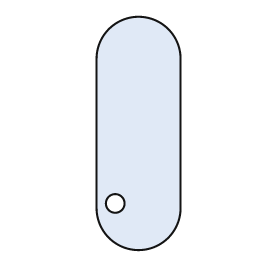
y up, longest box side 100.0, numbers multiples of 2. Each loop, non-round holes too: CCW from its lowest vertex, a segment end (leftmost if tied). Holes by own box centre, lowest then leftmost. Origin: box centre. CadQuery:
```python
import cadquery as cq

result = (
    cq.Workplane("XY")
    .moveTo(-18.0, -32.0)
    .threePointArc((0.0, -50.0), (18.0, -32.0))
    .lineTo(18.0, 32.0)
    .threePointArc((0.0, 50.0), (-18.0, 32.0))
    .close()
    .moveTo(-10.0, -30.0)
    .circle(4.0)
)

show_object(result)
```